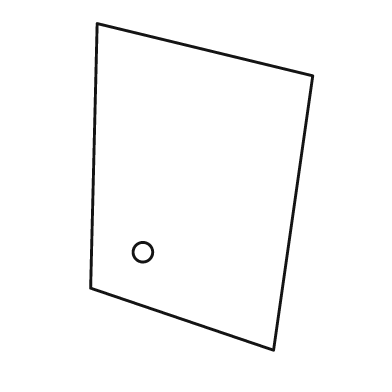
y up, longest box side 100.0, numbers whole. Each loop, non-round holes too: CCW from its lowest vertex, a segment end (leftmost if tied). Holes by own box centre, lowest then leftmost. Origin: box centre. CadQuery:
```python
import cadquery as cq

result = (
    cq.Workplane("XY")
    .moveTo(22.0, -50.0)
    .lineTo(34.0, 34.0)
    .lineTo(-32.0, 50.0)
    .lineTo(-34.0, -31.0)
    .close()
    .moveTo(-18.0, -20.0)
    .circle(3.0)
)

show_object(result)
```